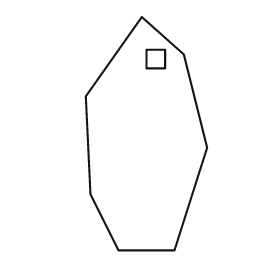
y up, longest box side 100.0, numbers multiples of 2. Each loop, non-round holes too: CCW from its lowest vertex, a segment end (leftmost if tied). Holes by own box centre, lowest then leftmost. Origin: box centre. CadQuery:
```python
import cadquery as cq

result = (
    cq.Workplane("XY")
    .moveTo(-12.0, -50.0)
    .lineTo(12.0, -50.0)
    .lineTo(26.0, -6.0)
    .lineTo(16.0, 34.0)
    .lineTo(-2.0, 50.0)
    .lineTo(-26.0, 16.0)
    .lineTo(-24.0, -26.0)
    .close()
    .moveTo(0.0, 28.0)
    .lineTo(8.0, 28.0)
    .lineTo(8.0, 36.0)
    .lineTo(0.0, 36.0)
    .close()
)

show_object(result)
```